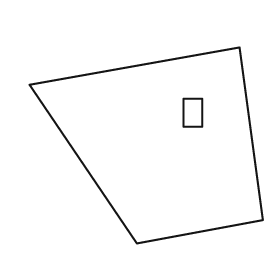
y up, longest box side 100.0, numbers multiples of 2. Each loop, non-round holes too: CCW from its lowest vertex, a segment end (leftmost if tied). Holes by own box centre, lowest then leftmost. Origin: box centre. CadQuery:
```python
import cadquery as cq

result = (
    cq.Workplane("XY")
    .moveTo(-4.0, -42.0)
    .lineTo(50.0, -32.0)
    .lineTo(40.0, 42.0)
    .lineTo(-50.0, 26.0)
    .close()
    .moveTo(16.0, 8.0)
    .lineTo(24.0, 8.0)
    .lineTo(24.0, 20.0)
    .lineTo(16.0, 20.0)
    .close()
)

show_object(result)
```